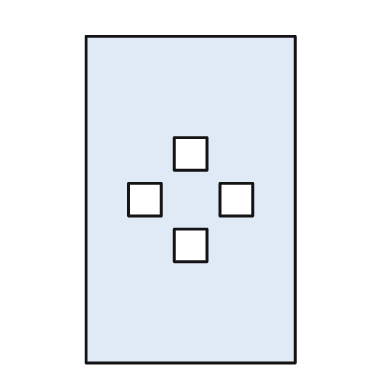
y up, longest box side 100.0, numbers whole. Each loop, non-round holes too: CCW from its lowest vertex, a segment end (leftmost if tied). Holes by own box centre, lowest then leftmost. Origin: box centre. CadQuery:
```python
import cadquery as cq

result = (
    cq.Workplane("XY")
    .moveTo(-32.0, -50.0)
    .lineTo(32.0, -50.0)
    .lineTo(32.0, 50.0)
    .lineTo(-32.0, 50.0)
    .close()
    .moveTo(-5.0, -19.0)
    .lineTo(5.0, -19.0)
    .lineTo(5.0, -9.0)
    .lineTo(-5.0, -9.0)
    .close()
    .moveTo(-19.0, -5.0)
    .lineTo(-9.0, -5.0)
    .lineTo(-9.0, 5.0)
    .lineTo(-19.0, 5.0)
    .close()
    .moveTo(9.0, -5.0)
    .lineTo(19.0, -5.0)
    .lineTo(19.0, 5.0)
    .lineTo(9.0, 5.0)
    .close()
    .moveTo(-5.0, 9.0)
    .lineTo(5.0, 9.0)
    .lineTo(5.0, 19.0)
    .lineTo(-5.0, 19.0)
    .close()
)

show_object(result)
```